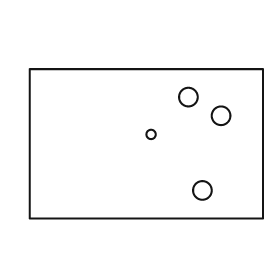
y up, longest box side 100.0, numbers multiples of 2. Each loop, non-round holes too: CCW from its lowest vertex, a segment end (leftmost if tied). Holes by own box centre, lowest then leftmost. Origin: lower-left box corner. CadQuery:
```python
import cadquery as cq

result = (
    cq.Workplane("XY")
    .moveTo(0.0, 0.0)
    .lineTo(100.0, 0.0)
    .lineTo(100.0, 64.0)
    .lineTo(0.0, 64.0)
    .close()
    .moveTo(74.0, 12.0)
    .circle(4.0)
    .moveTo(52.0, 36.0)
    .circle(2.0)
    .moveTo(82.0, 44.0)
    .circle(4.0)
    .moveTo(68.0, 52.0)
    .circle(4.0)
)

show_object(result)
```